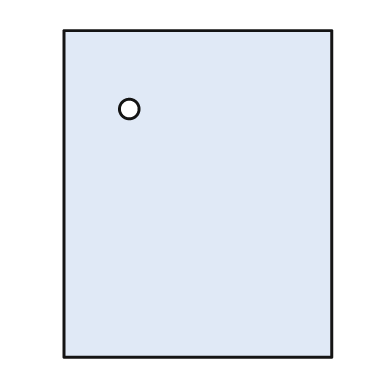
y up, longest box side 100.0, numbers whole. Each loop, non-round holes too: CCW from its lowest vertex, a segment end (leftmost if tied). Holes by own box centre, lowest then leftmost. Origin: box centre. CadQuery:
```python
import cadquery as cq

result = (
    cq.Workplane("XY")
    .moveTo(-41.0, -50.0)
    .lineTo(41.0, -50.0)
    .lineTo(41.0, 50.0)
    .lineTo(-41.0, 50.0)
    .close()
    .moveTo(-21.0, 26.0)
    .circle(3.0)
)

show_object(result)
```